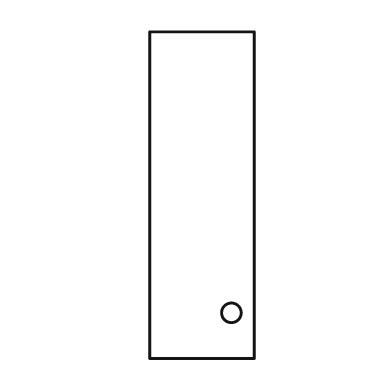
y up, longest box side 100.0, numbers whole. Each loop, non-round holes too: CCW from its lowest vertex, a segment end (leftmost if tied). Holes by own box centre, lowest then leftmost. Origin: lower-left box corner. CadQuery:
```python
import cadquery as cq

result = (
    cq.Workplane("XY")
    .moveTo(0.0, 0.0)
    .lineTo(32.0, 0.0)
    .lineTo(32.0, 100.0)
    .lineTo(0.0, 100.0)
    .close()
    .moveTo(25.0, 14.0)
    .circle(3.0)
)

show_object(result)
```